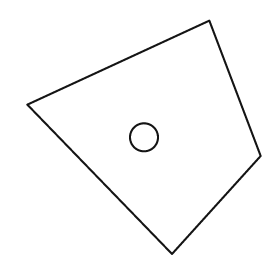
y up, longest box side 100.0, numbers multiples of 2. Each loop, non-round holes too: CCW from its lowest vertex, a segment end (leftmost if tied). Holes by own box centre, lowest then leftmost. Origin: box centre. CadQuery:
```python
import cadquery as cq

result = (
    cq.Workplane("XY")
    .moveTo(12.0, -50.0)
    .lineTo(50.0, -8.0)
    .lineTo(28.0, 50.0)
    .lineTo(-50.0, 14.0)
    .close()
    .moveTo(0.0, 0.0)
    .circle(6.0)
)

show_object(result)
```